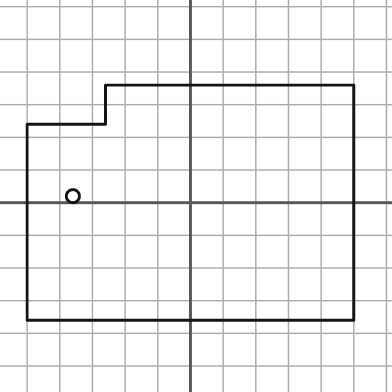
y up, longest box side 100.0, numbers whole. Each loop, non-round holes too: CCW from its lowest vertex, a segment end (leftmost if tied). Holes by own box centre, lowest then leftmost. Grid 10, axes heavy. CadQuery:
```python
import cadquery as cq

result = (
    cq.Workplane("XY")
    .moveTo(-50.0, -36.0)
    .lineTo(50.0, -36.0)
    .lineTo(50.0, 36.0)
    .lineTo(-26.0, 36.0)
    .lineTo(-26.0, 24.0)
    .lineTo(-50.0, 24.0)
    .close()
    .moveTo(-36.0, 2.0)
    .circle(2.0)
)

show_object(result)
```